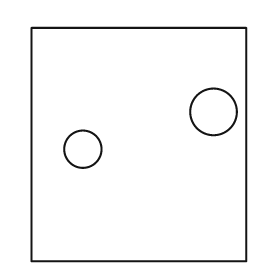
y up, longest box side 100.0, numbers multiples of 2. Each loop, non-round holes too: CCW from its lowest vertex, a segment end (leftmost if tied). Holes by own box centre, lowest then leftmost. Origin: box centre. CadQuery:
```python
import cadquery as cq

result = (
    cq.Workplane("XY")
    .moveTo(-46.0, -50.0)
    .lineTo(46.0, -50.0)
    .lineTo(46.0, 50.0)
    .lineTo(-46.0, 50.0)
    .close()
    .moveTo(-24.0, -2.0)
    .circle(8.0)
    .moveTo(32.0, 14.0)
    .circle(10.0)
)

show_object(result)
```